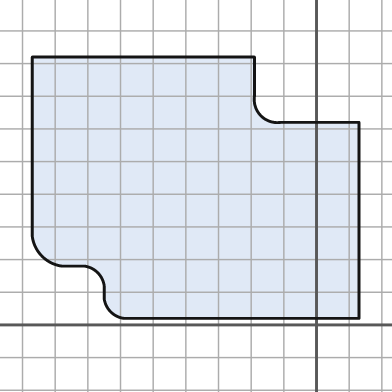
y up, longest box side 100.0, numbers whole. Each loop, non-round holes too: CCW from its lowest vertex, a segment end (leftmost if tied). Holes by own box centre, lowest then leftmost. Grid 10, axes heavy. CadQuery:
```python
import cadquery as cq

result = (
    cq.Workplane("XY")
    .moveTo(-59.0, 2.0)
    .lineTo(13.0, 2.0)
    .lineTo(13.0, 62.0)
    .lineTo(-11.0, 62.0)
    .threePointArc((-17.0, 64.0), (-19.0, 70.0))
    .lineTo(-19.0, 82.0)
    .lineTo(-87.0, 82.0)
    .lineTo(-87.0, 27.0)
    .threePointArc((-84.0, 21.0), (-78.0, 18.0))
    .lineTo(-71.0, 18.0)
    .threePointArc((-67.0, 16.0), (-65.0, 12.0))
    .lineTo(-65.0, 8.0)
    .threePointArc((-63.0, 4.0), (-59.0, 2.0))
    .close()
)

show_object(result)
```